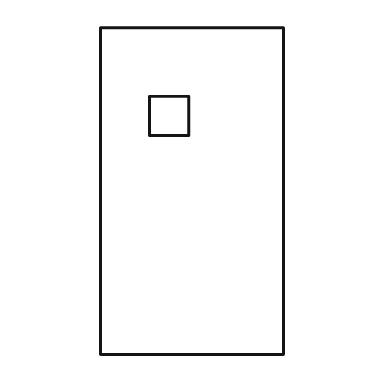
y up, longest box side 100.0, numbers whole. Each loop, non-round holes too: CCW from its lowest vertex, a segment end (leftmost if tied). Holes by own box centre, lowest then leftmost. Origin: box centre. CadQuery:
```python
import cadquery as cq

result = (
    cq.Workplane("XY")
    .moveTo(-28.0, -50.0)
    .lineTo(28.0, -50.0)
    .lineTo(28.0, 50.0)
    .lineTo(-28.0, 50.0)
    .close()
    .moveTo(-13.0, 17.0)
    .lineTo(-1.0, 17.0)
    .lineTo(-1.0, 29.0)
    .lineTo(-13.0, 29.0)
    .close()
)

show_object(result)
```